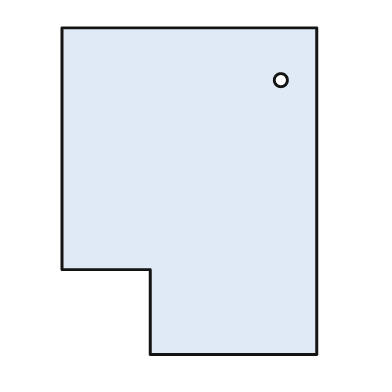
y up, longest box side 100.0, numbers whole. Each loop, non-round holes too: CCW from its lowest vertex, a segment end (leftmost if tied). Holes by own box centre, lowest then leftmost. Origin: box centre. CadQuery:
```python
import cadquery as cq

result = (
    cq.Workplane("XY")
    .moveTo(-12.0, -50.0)
    .lineTo(39.0, -50.0)
    .lineTo(39.0, 50.0)
    .lineTo(-39.0, 50.0)
    .lineTo(-39.0, -24.0)
    .lineTo(-12.0, -24.0)
    .close()
    .moveTo(28.0, 34.0)
    .circle(2.0)
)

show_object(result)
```